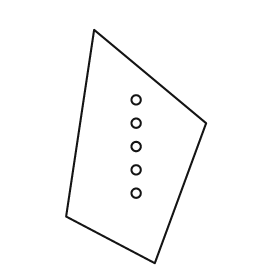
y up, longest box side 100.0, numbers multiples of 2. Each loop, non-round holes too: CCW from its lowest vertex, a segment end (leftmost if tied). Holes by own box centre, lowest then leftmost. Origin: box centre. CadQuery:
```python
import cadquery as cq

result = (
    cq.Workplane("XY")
    .moveTo(8.0, -50.0)
    .lineTo(30.0, 10.0)
    .lineTo(-18.0, 50.0)
    .lineTo(-30.0, -30.0)
    .close()
    .moveTo(0.0, -20.0)
    .circle(2.0)
    .moveTo(0.0, -10.0)
    .circle(2.0)
    .moveTo(0.0, 0.0)
    .circle(2.0)
    .moveTo(0.0, 10.0)
    .circle(2.0)
    .moveTo(0.0, 20.0)
    .circle(2.0)
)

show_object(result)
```